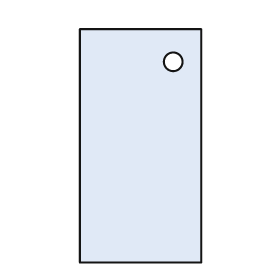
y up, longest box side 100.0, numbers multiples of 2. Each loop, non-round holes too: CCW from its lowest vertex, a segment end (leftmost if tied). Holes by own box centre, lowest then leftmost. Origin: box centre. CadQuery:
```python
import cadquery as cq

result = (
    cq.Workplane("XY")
    .moveTo(-26.0, -50.0)
    .lineTo(26.0, -50.0)
    .lineTo(26.0, 50.0)
    .lineTo(-26.0, 50.0)
    .close()
    .moveTo(14.0, 36.0)
    .circle(4.0)
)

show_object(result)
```